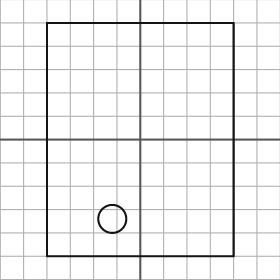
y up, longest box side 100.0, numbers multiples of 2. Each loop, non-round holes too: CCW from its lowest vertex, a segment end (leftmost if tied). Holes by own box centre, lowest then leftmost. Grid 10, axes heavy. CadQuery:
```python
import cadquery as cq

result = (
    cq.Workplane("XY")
    .moveTo(-40.0, -50.0)
    .lineTo(40.0, -50.0)
    .lineTo(40.0, 50.0)
    .lineTo(-40.0, 50.0)
    .close()
    .moveTo(-12.0, -34.0)
    .circle(6.0)
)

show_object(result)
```